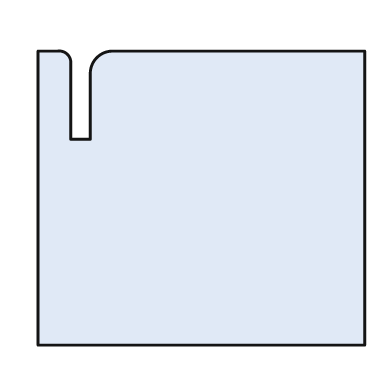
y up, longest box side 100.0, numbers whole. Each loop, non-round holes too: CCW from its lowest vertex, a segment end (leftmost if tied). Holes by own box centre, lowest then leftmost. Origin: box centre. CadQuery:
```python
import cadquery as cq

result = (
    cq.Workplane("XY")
    .moveTo(-50.0, -45.0)
    .lineTo(50.0, -45.0)
    .lineTo(50.0, 45.0)
    .lineTo(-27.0, 45.0)
    .threePointArc((-32.0, 43.0), (-34.0, 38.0))
    .lineTo(-34.0, 18.0)
    .lineTo(-40.0, 18.0)
    .lineTo(-40.0, 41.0)
    .threePointArc((-41.0, 44.0), (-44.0, 45.0))
    .lineTo(-50.0, 45.0)
    .close()
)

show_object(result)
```